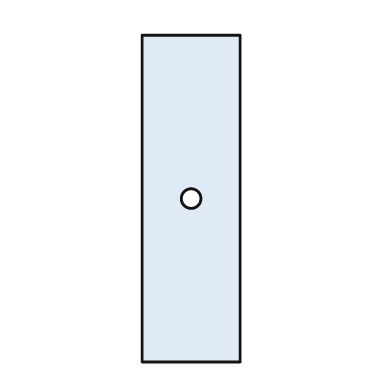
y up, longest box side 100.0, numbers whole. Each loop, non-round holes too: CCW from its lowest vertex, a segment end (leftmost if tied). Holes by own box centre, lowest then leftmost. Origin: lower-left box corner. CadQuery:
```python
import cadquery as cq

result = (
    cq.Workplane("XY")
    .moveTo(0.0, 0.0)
    .lineTo(30.0, 0.0)
    .lineTo(30.0, 100.0)
    .lineTo(0.0, 100.0)
    .close()
    .moveTo(15.0, 50.0)
    .circle(3.0)
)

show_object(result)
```